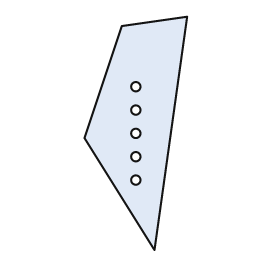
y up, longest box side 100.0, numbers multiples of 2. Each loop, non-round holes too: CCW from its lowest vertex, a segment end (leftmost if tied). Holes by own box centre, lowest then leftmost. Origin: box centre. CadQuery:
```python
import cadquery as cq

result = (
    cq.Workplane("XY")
    .moveTo(8.0, -50.0)
    .lineTo(22.0, 50.0)
    .lineTo(-6.0, 46.0)
    .lineTo(-22.0, -2.0)
    .close()
    .moveTo(0.0, -20.0)
    .circle(2.0)
    .moveTo(0.0, -10.0)
    .circle(2.0)
    .moveTo(0.0, 0.0)
    .circle(2.0)
    .moveTo(0.0, 10.0)
    .circle(2.0)
    .moveTo(0.0, 20.0)
    .circle(2.0)
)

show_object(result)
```